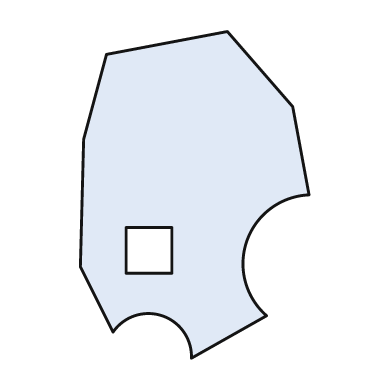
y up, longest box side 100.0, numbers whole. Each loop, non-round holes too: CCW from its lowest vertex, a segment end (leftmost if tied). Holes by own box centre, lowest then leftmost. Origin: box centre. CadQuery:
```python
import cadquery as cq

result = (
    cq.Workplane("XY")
    .moveTo(-1.0, -50.0)
    .lineTo(22.0, -37.0)
    .threePointArc((16.0, -14.0), (35.0, 0.0))
    .lineTo(30.0, 27.0)
    .lineTo(10.0, 50.0)
    .lineTo(-27.0, 43.0)
    .lineTo(-34.0, 17.0)
    .lineTo(-35.0, -22.0)
    .lineTo(-25.0, -42.0)
    .threePointArc((-10.0, -37.0), (-1.0, -50.0))
    .close()
    .moveTo(-21.0, -24.0)
    .lineTo(-7.0, -24.0)
    .lineTo(-7.0, -10.0)
    .lineTo(-21.0, -10.0)
    .close()
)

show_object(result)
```